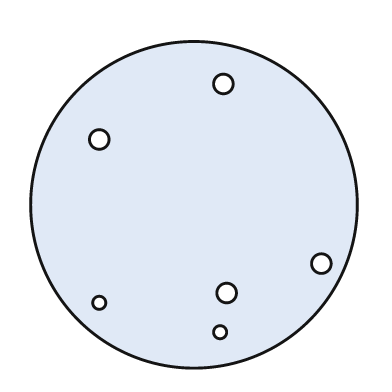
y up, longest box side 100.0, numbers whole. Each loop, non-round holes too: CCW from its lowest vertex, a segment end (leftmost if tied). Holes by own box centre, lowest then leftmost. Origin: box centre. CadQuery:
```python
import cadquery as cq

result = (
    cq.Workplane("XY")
    .moveTo(0.0, 0.0)
    .circle(50.0)
    .moveTo(8.0, -39.0)
    .circle(2.0)
    .moveTo(-29.0, -30.0)
    .circle(2.0)
    .moveTo(10.0, -27.0)
    .circle(3.0)
    .moveTo(39.0, -18.0)
    .circle(3.0)
    .moveTo(-29.0, 20.0)
    .circle(3.0)
    .moveTo(9.0, 37.0)
    .circle(3.0)
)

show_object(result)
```